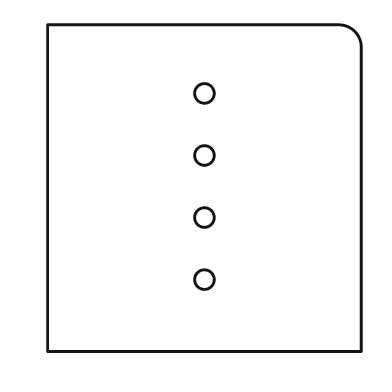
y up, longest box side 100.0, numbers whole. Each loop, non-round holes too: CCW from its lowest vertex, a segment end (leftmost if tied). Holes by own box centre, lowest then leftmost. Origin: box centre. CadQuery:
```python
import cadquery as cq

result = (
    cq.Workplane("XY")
    .moveTo(-48.0, -50.0)
    .lineTo(48.0, -50.0)
    .lineTo(48.0, 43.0)
    .threePointArc((46.0, 48.0), (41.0, 50.0))
    .lineTo(-48.0, 50.0)
    .close()
    .moveTo(0.0, -28.0)
    .circle(3.0)
    .moveTo(0.0, -9.0)
    .circle(3.0)
    .moveTo(0.0, 10.0)
    .circle(3.0)
    .moveTo(0.0, 29.0)
    .circle(3.0)
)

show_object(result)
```